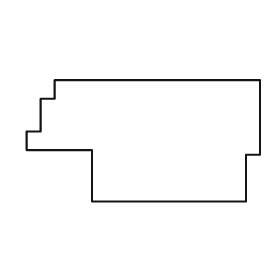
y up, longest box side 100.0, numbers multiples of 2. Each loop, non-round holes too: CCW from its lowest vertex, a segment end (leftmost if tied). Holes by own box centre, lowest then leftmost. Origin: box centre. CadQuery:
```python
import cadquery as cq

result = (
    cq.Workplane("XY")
    .moveTo(-22.0, -26.0)
    .lineTo(44.0, -26.0)
    .lineTo(44.0, -6.0)
    .lineTo(50.0, -6.0)
    .lineTo(50.0, 26.0)
    .lineTo(-38.0, 26.0)
    .lineTo(-38.0, 18.0)
    .lineTo(-44.0, 18.0)
    .lineTo(-44.0, 4.0)
    .lineTo(-50.0, 4.0)
    .lineTo(-50.0, -4.0)
    .lineTo(-22.0, -4.0)
    .close()
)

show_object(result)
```